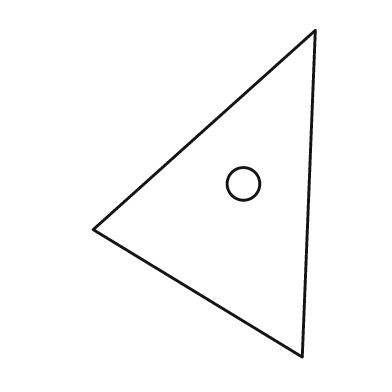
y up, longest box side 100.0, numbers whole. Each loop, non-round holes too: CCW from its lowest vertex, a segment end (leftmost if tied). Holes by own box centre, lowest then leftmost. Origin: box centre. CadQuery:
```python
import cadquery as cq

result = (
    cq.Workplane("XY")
    .moveTo(30.0, -50.0)
    .lineTo(34.0, 50.0)
    .lineTo(-34.0, -11.0)
    .close()
    .moveTo(12.0, 3.0)
    .circle(5.0)
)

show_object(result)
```